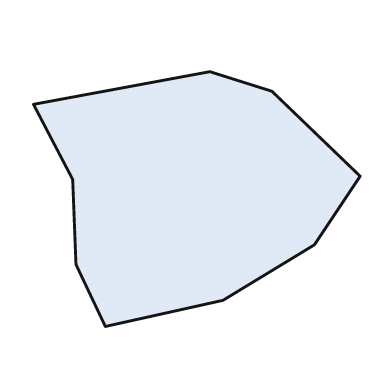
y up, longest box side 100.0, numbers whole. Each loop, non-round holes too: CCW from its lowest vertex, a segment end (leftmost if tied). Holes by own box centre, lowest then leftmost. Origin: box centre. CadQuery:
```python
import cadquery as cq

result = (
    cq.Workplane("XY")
    .moveTo(-28.0, -39.0)
    .lineTo(8.0, -31.0)
    .lineTo(36.0, -14.0)
    .lineTo(50.0, 7.0)
    .lineTo(23.0, 33.0)
    .lineTo(4.0, 39.0)
    .lineTo(-50.0, 29.0)
    .lineTo(-38.0, 6.0)
    .lineTo(-37.0, -20.0)
    .close()
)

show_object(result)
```